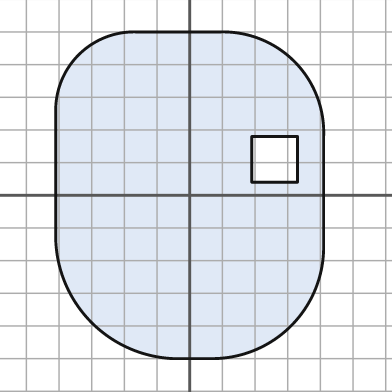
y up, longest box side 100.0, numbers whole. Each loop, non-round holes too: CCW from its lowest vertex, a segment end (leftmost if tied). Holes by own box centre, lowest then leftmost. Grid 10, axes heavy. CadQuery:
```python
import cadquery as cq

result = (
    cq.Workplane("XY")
    .moveTo(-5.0, -50.0)
    .lineTo(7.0, -50.0)
    .threePointArc((31.0, -40.0), (41.0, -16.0))
    .lineTo(41.0, 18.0)
    .threePointArc((32.0, 41.0), (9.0, 50.0))
    .lineTo(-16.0, 50.0)
    .threePointArc((-34.0, 43.0), (-41.0, 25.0))
    .lineTo(-41.0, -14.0)
    .threePointArc((-30.0, -39.0), (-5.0, -50.0))
    .close()
    .moveTo(19.0, 4.0)
    .lineTo(33.0, 4.0)
    .lineTo(33.0, 18.0)
    .lineTo(19.0, 18.0)
    .close()
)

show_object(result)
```